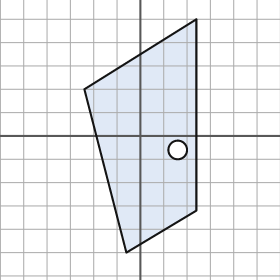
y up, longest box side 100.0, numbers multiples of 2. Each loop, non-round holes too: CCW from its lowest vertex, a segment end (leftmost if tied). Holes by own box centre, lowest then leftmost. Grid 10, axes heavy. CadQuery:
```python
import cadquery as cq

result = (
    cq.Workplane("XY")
    .moveTo(-6.0, -50.0)
    .lineTo(24.0, -32.0)
    .lineTo(24.0, 50.0)
    .lineTo(-24.0, 20.0)
    .close()
    .moveTo(16.0, -6.0)
    .circle(4.0)
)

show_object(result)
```